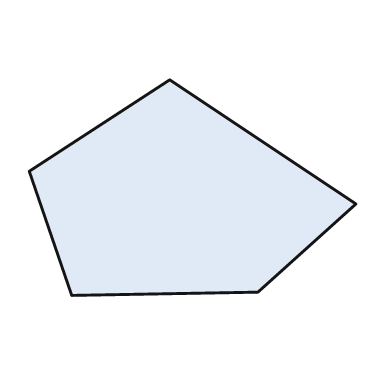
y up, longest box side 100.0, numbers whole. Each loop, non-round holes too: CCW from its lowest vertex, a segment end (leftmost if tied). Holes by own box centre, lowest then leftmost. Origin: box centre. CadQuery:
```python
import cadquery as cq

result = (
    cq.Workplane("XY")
    .moveTo(-37.0, -33.0)
    .lineTo(20.0, -32.0)
    .lineTo(50.0, -5.0)
    .lineTo(-7.0, 33.0)
    .lineTo(-50.0, 5.0)
    .close()
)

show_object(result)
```